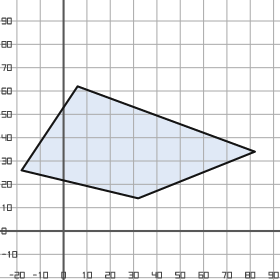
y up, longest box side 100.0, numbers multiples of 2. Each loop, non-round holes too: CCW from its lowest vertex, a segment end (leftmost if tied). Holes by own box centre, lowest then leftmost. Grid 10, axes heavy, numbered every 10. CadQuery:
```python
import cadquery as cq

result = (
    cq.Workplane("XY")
    .moveTo(32.0, 14.0)
    .lineTo(82.0, 34.0)
    .lineTo(6.0, 62.0)
    .lineTo(-18.0, 26.0)
    .close()
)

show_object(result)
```